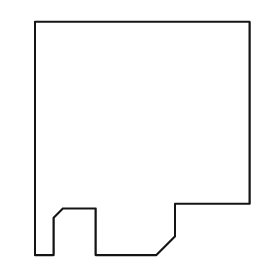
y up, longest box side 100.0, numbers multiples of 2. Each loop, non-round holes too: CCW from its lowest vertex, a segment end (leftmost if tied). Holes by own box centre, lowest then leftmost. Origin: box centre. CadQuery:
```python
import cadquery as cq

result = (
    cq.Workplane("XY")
    .moveTo(-46.0, -50.0)
    .lineTo(-38.0, -50.0)
    .lineTo(-38.0, -34.0)
    .lineTo(-34.0, -30.0)
    .lineTo(-20.0, -30.0)
    .lineTo(-20.0, -50.0)
    .lineTo(6.0, -50.0)
    .lineTo(14.0, -42.0)
    .lineTo(14.0, -28.0)
    .lineTo(46.0, -28.0)
    .lineTo(46.0, 50.0)
    .lineTo(-46.0, 50.0)
    .close()
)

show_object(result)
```